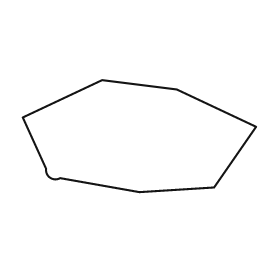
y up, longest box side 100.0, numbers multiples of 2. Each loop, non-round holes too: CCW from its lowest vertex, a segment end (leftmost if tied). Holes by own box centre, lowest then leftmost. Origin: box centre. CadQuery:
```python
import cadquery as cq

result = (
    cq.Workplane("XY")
    .moveTo(0.0, -24.0)
    .lineTo(32.0, -22.0)
    .lineTo(50.0, 4.0)
    .lineTo(16.0, 20.0)
    .lineTo(-16.0, 24.0)
    .lineTo(-50.0, 8.0)
    .lineTo(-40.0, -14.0)
    .threePointArc((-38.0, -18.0), (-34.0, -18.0))
    .close()
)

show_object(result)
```